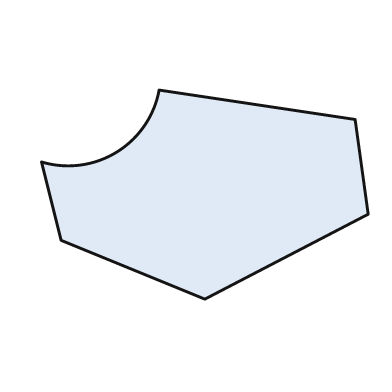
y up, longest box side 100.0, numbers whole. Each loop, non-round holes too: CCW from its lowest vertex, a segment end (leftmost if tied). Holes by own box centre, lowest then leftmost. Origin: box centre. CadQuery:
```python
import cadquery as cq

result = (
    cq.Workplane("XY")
    .moveTo(0.0, -32.0)
    .lineTo(50.0, -6.0)
    .lineTo(46.0, 23.0)
    .lineTo(-14.0, 32.0)
    .threePointArc((-27.0, 13.0), (-50.0, 10.0))
    .lineTo(-44.0, -14.0)
    .close()
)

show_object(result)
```